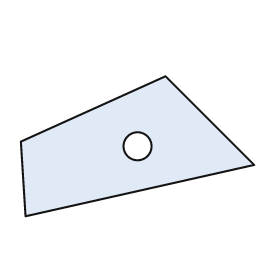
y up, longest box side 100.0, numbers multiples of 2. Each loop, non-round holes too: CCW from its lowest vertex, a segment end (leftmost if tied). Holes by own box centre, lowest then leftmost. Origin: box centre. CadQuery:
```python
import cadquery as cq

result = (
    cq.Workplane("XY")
    .moveTo(-48.0, -30.0)
    .lineTo(50.0, -8.0)
    .lineTo(12.0, 30.0)
    .lineTo(-50.0, 2.0)
    .close()
    .moveTo(0.0, 0.0)
    .circle(6.0)
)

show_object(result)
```